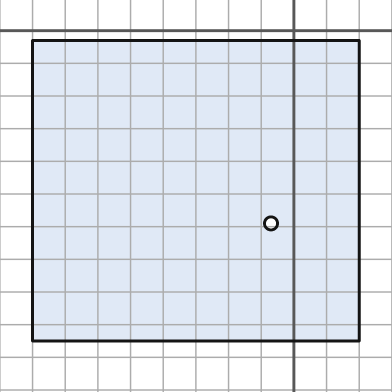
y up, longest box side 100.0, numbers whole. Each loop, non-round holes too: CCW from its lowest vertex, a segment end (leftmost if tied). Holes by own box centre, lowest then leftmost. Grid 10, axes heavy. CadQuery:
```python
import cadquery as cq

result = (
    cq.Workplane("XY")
    .moveTo(-80.0, -95.0)
    .lineTo(20.0, -95.0)
    .lineTo(20.0, -3.0)
    .lineTo(-80.0, -3.0)
    .close()
    .moveTo(-7.0, -59.0)
    .circle(2.0)
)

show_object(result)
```